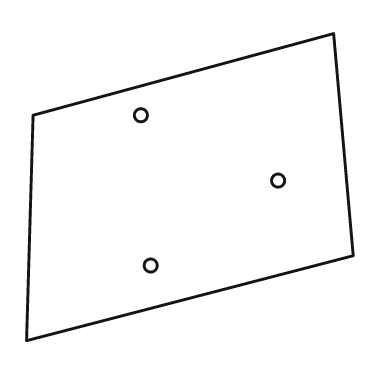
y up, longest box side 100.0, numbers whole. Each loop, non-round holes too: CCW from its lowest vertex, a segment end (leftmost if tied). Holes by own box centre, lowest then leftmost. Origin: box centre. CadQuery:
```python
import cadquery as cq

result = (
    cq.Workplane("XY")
    .moveTo(-50.0, -47.0)
    .lineTo(50.0, -21.0)
    .lineTo(44.0, 47.0)
    .lineTo(-48.0, 22.0)
    .close()
    .moveTo(-12.0, -24.0)
    .circle(2.0)
    .moveTo(27.0, 2.0)
    .circle(2.0)
    .moveTo(-15.0, 22.0)
    .circle(2.0)
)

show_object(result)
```